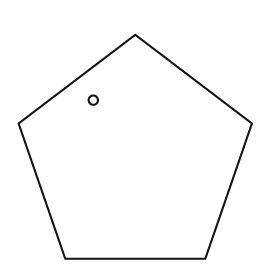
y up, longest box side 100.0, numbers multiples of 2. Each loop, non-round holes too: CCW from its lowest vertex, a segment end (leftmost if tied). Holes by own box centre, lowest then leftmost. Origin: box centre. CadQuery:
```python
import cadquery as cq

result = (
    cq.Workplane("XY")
    .moveTo(-30.0, -48.0)
    .lineTo(30.0, -48.0)
    .lineTo(50.0, 10.0)
    .lineTo(0.0, 48.0)
    .lineTo(-50.0, 10.0)
    .close()
    .moveTo(-18.0, 20.0)
    .circle(2.0)
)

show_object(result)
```